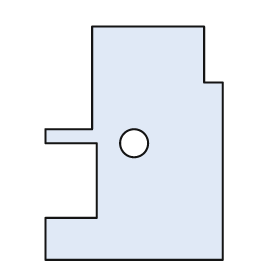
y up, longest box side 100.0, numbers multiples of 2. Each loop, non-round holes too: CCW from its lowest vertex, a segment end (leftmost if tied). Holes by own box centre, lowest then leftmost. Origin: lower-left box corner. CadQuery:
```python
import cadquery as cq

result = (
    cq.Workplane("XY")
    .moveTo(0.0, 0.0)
    .lineTo(76.0, 0.0)
    .lineTo(76.0, 76.0)
    .lineTo(68.0, 76.0)
    .lineTo(68.0, 100.0)
    .lineTo(20.0, 100.0)
    .lineTo(20.0, 56.0)
    .lineTo(0.0, 56.0)
    .lineTo(0.0, 50.0)
    .lineTo(22.0, 50.0)
    .lineTo(22.0, 18.0)
    .lineTo(0.0, 18.0)
    .close()
    .moveTo(38.0, 50.0)
    .circle(6.0)
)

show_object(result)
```